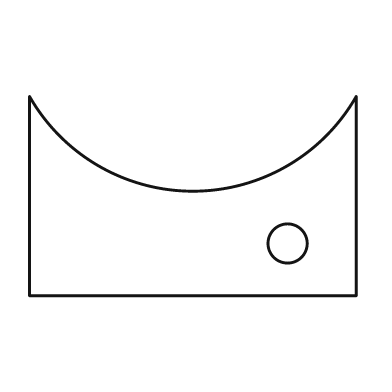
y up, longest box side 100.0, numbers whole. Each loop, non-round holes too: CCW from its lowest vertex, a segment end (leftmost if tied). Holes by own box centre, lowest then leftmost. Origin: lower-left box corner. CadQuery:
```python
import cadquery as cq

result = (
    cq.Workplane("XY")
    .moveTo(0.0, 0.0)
    .lineTo(100.0, 0.0)
    .lineTo(100.0, 61.0)
    .threePointArc((50.0, 32.0), (0.0, 61.0))
    .close()
    .moveTo(79.0, 16.0)
    .circle(6.0)
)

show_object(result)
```